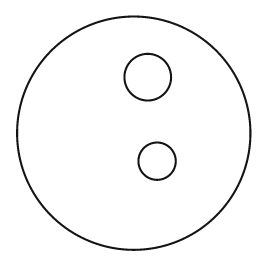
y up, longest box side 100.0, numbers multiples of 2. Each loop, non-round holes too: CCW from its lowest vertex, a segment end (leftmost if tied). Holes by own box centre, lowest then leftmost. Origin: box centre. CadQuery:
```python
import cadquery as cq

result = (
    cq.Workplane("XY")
    .moveTo(0.0, 0.0)
    .circle(50.0)
    .moveTo(10.0, -12.0)
    .circle(8.0)
    .moveTo(6.0, 24.0)
    .circle(10.0)
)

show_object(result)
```